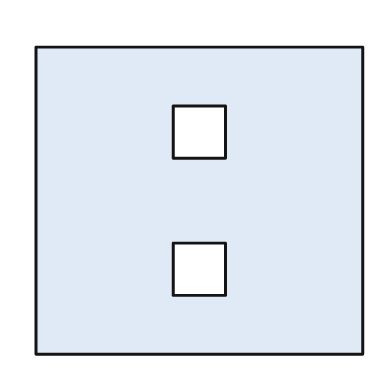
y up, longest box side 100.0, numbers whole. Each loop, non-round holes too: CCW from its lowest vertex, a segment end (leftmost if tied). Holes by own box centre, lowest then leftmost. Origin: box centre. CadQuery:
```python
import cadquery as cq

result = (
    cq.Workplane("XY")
    .moveTo(-50.0, -47.0)
    .lineTo(50.0, -47.0)
    .lineTo(50.0, 47.0)
    .lineTo(-50.0, 47.0)
    .close()
    .moveTo(-8.0, -29.0)
    .lineTo(8.0, -29.0)
    .lineTo(8.0, -13.0)
    .lineTo(-8.0, -13.0)
    .close()
    .moveTo(-8.0, 13.0)
    .lineTo(8.0, 13.0)
    .lineTo(8.0, 29.0)
    .lineTo(-8.0, 29.0)
    .close()
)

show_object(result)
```